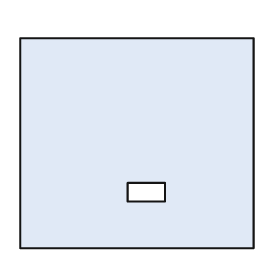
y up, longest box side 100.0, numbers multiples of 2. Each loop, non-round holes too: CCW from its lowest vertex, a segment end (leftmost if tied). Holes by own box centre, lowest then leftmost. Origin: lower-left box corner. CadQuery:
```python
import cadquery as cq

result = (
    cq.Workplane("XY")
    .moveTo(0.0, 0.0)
    .lineTo(100.0, 0.0)
    .lineTo(100.0, 90.0)
    .lineTo(0.0, 90.0)
    .close()
    .moveTo(46.0, 20.0)
    .lineTo(62.0, 20.0)
    .lineTo(62.0, 28.0)
    .lineTo(46.0, 28.0)
    .close()
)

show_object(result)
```